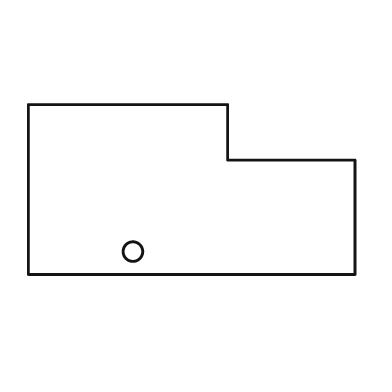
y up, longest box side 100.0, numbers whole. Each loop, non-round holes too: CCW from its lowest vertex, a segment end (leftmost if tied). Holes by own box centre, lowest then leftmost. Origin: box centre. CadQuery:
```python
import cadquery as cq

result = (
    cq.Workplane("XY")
    .moveTo(-50.0, -26.0)
    .lineTo(50.0, -26.0)
    .lineTo(50.0, 9.0)
    .lineTo(11.0, 9.0)
    .lineTo(11.0, 26.0)
    .lineTo(-50.0, 26.0)
    .close()
    .moveTo(-18.0, -19.0)
    .circle(3.0)
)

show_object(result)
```